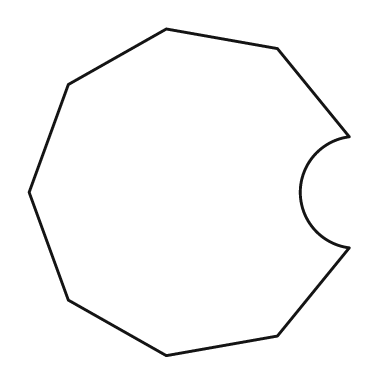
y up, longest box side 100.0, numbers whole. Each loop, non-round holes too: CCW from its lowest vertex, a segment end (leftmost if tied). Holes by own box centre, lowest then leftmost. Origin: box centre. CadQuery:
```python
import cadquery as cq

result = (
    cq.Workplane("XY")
    .moveTo(-7.0, -50.0)
    .lineTo(27.0, -44.0)
    .lineTo(49.0, -17.0)
    .threePointArc((34.0, 0.0), (49.0, 17.0))
    .lineTo(27.0, 44.0)
    .lineTo(-7.0, 50.0)
    .lineTo(-37.0, 33.0)
    .lineTo(-49.0, 0.0)
    .lineTo(-37.0, -33.0)
    .close()
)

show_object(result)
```